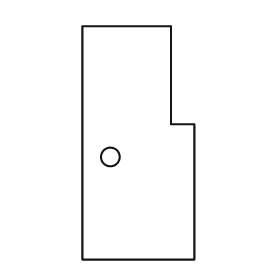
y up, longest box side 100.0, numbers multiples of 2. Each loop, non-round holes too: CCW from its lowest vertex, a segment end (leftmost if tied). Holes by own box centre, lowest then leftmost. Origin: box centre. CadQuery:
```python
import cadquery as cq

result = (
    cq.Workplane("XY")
    .moveTo(-24.0, -50.0)
    .lineTo(24.0, -50.0)
    .lineTo(24.0, 8.0)
    .lineTo(14.0, 8.0)
    .lineTo(14.0, 50.0)
    .lineTo(-24.0, 50.0)
    .close()
    .moveTo(-12.0, -6.0)
    .circle(4.0)
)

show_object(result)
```